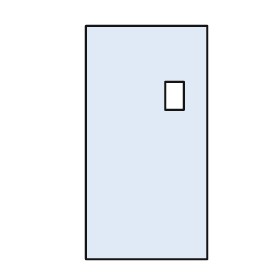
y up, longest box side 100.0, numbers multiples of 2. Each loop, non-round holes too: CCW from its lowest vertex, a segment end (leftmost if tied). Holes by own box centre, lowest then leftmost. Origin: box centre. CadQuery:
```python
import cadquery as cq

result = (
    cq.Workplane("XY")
    .moveTo(-26.0, -50.0)
    .lineTo(26.0, -50.0)
    .lineTo(26.0, 50.0)
    .lineTo(-26.0, 50.0)
    .close()
    .moveTo(8.0, 14.0)
    .lineTo(16.0, 14.0)
    .lineTo(16.0, 26.0)
    .lineTo(8.0, 26.0)
    .close()
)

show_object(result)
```